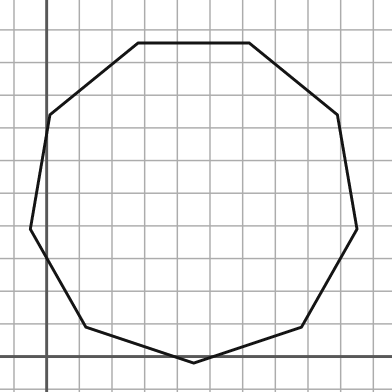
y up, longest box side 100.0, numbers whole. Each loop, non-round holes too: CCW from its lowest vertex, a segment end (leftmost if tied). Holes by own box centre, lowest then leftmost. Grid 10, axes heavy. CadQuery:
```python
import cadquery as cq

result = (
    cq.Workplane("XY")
    .moveTo(45.0, -2.0)
    .lineTo(78.0, 9.0)
    .lineTo(95.0, 39.0)
    .lineTo(89.0, 74.0)
    .lineTo(62.0, 96.0)
    .lineTo(28.0, 96.0)
    .lineTo(1.0, 74.0)
    .lineTo(-5.0, 39.0)
    .lineTo(12.0, 9.0)
    .close()
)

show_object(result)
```